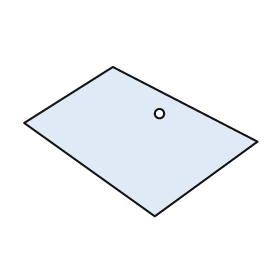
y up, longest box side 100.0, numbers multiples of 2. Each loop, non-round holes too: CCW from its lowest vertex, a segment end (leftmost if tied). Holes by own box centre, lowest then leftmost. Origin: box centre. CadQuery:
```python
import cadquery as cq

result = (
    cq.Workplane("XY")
    .moveTo(6.0, -32.0)
    .lineTo(50.0, 0.0)
    .lineTo(-12.0, 32.0)
    .lineTo(-50.0, 8.0)
    .close()
    .moveTo(8.0, 12.0)
    .circle(2.0)
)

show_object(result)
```